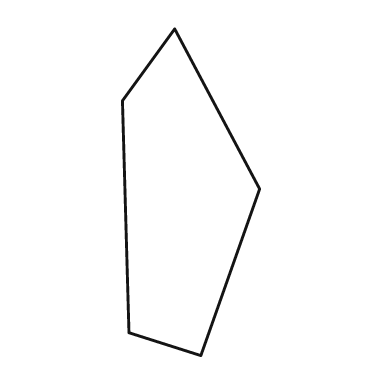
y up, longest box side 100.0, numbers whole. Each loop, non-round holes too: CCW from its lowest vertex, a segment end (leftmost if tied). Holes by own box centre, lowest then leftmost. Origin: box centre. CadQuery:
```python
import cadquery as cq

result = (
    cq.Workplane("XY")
    .moveTo(3.0, -50.0)
    .lineTo(21.0, 1.0)
    .lineTo(-5.0, 50.0)
    .lineTo(-21.0, 28.0)
    .lineTo(-19.0, -43.0)
    .close()
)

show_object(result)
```